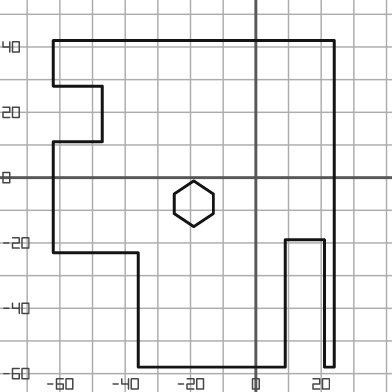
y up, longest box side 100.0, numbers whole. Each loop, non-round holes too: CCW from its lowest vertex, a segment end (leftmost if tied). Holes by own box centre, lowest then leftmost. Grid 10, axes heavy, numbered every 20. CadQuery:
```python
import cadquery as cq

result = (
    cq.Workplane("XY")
    .moveTo(-36.0, -58.0)
    .lineTo(9.0, -58.0)
    .lineTo(9.0, -19.0)
    .lineTo(21.0, -19.0)
    .lineTo(21.0, -58.0)
    .lineTo(24.0, -58.0)
    .lineTo(24.0, 42.0)
    .lineTo(-62.0, 42.0)
    .lineTo(-62.0, 28.0)
    .lineTo(-47.0, 28.0)
    .lineTo(-47.0, 11.0)
    .lineTo(-62.0, 11.0)
    .lineTo(-62.0, -23.0)
    .lineTo(-36.0, -23.0)
    .close()
    .moveTo(-19.0, -15.0)
    .lineTo(-13.0, -11.0)
    .lineTo(-13.0, -5.0)
    .lineTo(-19.0, -1.0)
    .lineTo(-25.0, -5.0)
    .lineTo(-25.0, -11.0)
    .close()
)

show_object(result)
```